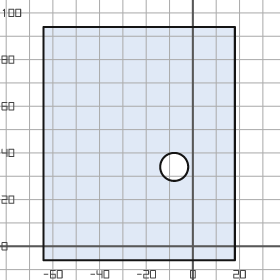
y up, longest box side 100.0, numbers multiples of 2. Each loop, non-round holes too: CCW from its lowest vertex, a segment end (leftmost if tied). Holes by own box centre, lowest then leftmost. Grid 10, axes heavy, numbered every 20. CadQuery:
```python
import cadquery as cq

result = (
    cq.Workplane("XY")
    .moveTo(-64.0, -6.0)
    .lineTo(18.0, -6.0)
    .lineTo(18.0, 94.0)
    .lineTo(-64.0, 94.0)
    .close()
    .moveTo(-8.0, 34.0)
    .circle(6.0)
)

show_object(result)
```